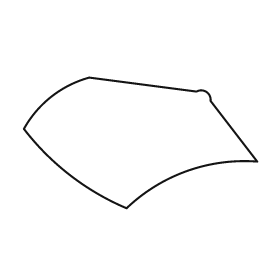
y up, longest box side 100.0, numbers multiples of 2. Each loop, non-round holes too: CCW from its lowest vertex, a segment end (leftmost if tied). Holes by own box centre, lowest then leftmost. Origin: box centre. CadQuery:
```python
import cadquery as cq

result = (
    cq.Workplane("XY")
    .moveTo(-6.0, -28.0)
    .threePointArc((20.0, -12.0), (50.0, -8.0))
    .lineTo(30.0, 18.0)
    .threePointArc((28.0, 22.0), (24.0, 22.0))
    .lineTo(-22.0, 28.0)
    .threePointArc((-38.0, 20.0), (-50.0, 6.0))
    .threePointArc((-30.0, -14.0), (-6.0, -28.0))
    .close()
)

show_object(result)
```